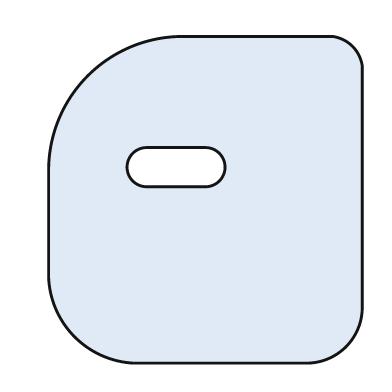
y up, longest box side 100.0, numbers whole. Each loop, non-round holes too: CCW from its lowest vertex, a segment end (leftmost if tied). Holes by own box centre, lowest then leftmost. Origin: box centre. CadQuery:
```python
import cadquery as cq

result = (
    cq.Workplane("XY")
    .moveTo(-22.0, -50.0)
    .lineTo(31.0, -50.0)
    .threePointArc((43.0, -45.0), (48.0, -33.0))
    .lineTo(48.0, 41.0)
    .threePointArc((45.0, 47.0), (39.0, 50.0))
    .lineTo(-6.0, 50.0)
    .threePointArc((-36.0, 38.0), (-48.0, 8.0))
    .lineTo(-48.0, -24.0)
    .threePointArc((-40.0, -42.0), (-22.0, -50.0))
    .close()
    .moveTo(-18.0, 4.0)
    .lineTo(0.0, 4.0)
    .threePointArc((6.0, 10.0), (0.0, 16.0))
    .lineTo(-18.0, 16.0)
    .threePointArc((-24.0, 10.0), (-18.0, 4.0))
    .close()
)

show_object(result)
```